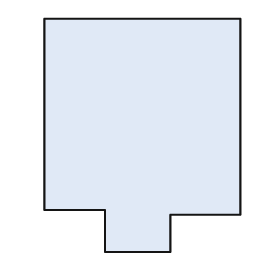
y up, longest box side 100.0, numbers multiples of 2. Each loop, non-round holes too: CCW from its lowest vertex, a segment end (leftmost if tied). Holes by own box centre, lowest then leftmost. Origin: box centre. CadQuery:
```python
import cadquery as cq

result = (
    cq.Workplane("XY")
    .moveTo(-16.0, -50.0)
    .lineTo(12.0, -50.0)
    .lineTo(12.0, -34.0)
    .lineTo(42.0, -34.0)
    .lineTo(42.0, 50.0)
    .lineTo(-42.0, 50.0)
    .lineTo(-42.0, -32.0)
    .lineTo(-16.0, -32.0)
    .close()
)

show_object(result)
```